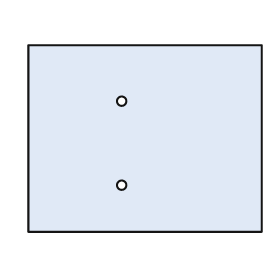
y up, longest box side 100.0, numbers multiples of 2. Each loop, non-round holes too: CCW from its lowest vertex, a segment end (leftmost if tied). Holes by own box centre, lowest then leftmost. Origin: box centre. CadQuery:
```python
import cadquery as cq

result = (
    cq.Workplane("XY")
    .moveTo(-50.0, -40.0)
    .lineTo(50.0, -40.0)
    .lineTo(50.0, 40.0)
    .lineTo(-50.0, 40.0)
    .close()
    .moveTo(-10.0, -20.0)
    .circle(2.0)
    .moveTo(-10.0, 16.0)
    .circle(2.0)
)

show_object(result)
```